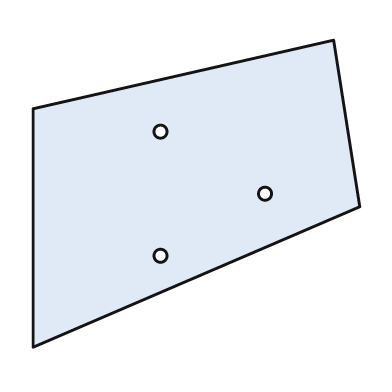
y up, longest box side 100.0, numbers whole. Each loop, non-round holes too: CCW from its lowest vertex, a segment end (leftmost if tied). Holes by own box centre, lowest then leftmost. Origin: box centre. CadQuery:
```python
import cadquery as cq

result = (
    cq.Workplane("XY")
    .moveTo(-50.0, -47.0)
    .lineTo(50.0, -4.0)
    .lineTo(42.0, 47.0)
    .lineTo(-50.0, 26.0)
    .close()
    .moveTo(-11.0, -19.0)
    .circle(2.0)
    .moveTo(21.0, 0.0)
    .circle(2.0)
    .moveTo(-11.0, 19.0)
    .circle(2.0)
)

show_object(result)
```